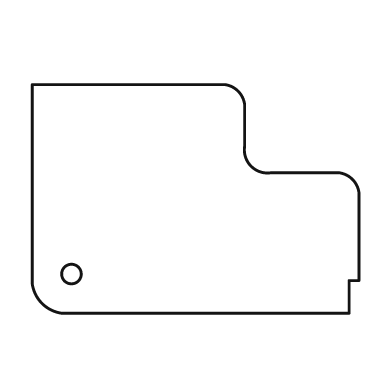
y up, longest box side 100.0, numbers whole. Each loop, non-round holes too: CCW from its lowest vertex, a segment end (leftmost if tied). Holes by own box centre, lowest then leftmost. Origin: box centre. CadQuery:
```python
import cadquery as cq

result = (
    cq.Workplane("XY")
    .moveTo(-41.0, -35.0)
    .lineTo(47.0, -35.0)
    .lineTo(47.0, -25.0)
    .lineTo(50.0, -25.0)
    .lineTo(50.0, 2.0)
    .threePointArc((48.0, 6.0), (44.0, 8.0))
    .lineTo(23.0, 8.0)
    .threePointArc((17.0, 10.0), (15.0, 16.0))
    .lineTo(15.0, 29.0)
    .threePointArc((13.0, 33.0), (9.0, 35.0))
    .lineTo(-50.0, 35.0)
    .lineTo(-50.0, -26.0)
    .threePointArc((-47.0, -32.0), (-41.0, -35.0))
    .close()
    .moveTo(-38.0, -23.0)
    .circle(3.0)
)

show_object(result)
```